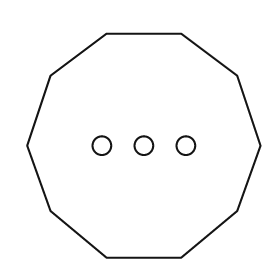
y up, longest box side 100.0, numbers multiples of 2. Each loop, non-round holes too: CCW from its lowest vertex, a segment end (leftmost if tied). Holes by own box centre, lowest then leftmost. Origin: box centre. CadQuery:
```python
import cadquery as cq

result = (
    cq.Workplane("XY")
    .moveTo(-16.0, -48.0)
    .lineTo(16.0, -48.0)
    .lineTo(40.0, -28.0)
    .lineTo(50.0, 0.0)
    .lineTo(40.0, 30.0)
    .lineTo(16.0, 48.0)
    .lineTo(-16.0, 48.0)
    .lineTo(-40.0, 30.0)
    .lineTo(-50.0, 0.0)
    .lineTo(-40.0, -28.0)
    .close()
    .moveTo(-18.0, 0.0)
    .circle(4.0)
    .moveTo(0.0, 0.0)
    .circle(4.0)
    .moveTo(18.0, 0.0)
    .circle(4.0)
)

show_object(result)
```